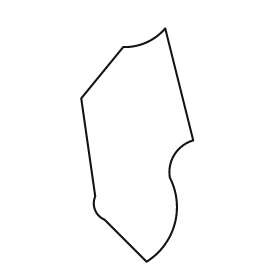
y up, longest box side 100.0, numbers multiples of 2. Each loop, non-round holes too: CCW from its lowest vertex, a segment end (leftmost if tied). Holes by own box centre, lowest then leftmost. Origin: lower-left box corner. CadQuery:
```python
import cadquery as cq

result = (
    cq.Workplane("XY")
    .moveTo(28.0, 0.0)
    .threePointArc((40.0, 16.0), (38.0, 36.0))
    .threePointArc((40.0, 46.0), (48.0, 52.0))
    .lineTo(36.0, 100.0)
    .threePointArc((28.0, 94.0), (18.0, 92.0))
    .lineTo(0.0, 70.0)
    .lineTo(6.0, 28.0)
    .threePointArc((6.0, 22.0), (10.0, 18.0))
    .close()
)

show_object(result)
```